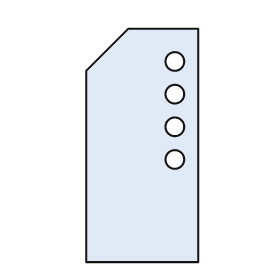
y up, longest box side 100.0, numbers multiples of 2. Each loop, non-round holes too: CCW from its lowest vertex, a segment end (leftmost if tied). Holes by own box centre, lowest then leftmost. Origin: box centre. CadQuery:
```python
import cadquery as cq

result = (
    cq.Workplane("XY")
    .moveTo(-24.0, -50.0)
    .lineTo(24.0, -50.0)
    .lineTo(24.0, 50.0)
    .lineTo(-6.0, 50.0)
    .lineTo(-24.0, 32.0)
    .close()
    .moveTo(14.0, -6.0)
    .circle(4.0)
    .moveTo(14.0, 8.0)
    .circle(4.0)
    .moveTo(14.0, 22.0)
    .circle(4.0)
    .moveTo(14.0, 36.0)
    .circle(4.0)
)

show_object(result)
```